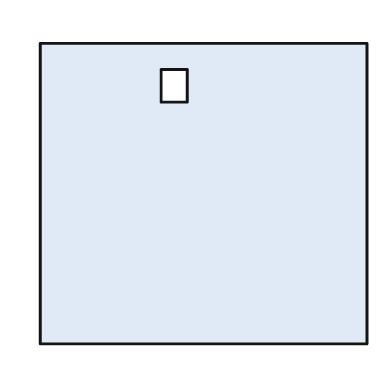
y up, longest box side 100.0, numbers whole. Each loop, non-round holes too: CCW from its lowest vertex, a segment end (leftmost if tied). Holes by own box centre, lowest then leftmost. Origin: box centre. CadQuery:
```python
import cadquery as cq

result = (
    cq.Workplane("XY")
    .moveTo(-50.0, -46.0)
    .lineTo(50.0, -46.0)
    .lineTo(50.0, 46.0)
    .lineTo(-50.0, 46.0)
    .close()
    .moveTo(-13.0, 28.0)
    .lineTo(-5.0, 28.0)
    .lineTo(-5.0, 38.0)
    .lineTo(-13.0, 38.0)
    .close()
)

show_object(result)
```